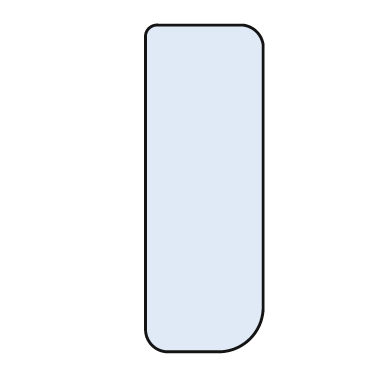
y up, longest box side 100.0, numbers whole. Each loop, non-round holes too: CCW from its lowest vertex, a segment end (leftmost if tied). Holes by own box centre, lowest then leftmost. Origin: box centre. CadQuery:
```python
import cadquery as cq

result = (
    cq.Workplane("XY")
    .moveTo(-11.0, -50.0)
    .lineTo(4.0, -50.0)
    .threePointArc((14.0, -46.0), (18.0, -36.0))
    .lineTo(18.0, 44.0)
    .threePointArc((16.0, 48.0), (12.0, 50.0))
    .lineTo(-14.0, 50.0)
    .threePointArc((-17.0, 49.0), (-18.0, 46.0))
    .lineTo(-18.0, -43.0)
    .threePointArc((-16.0, -48.0), (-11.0, -50.0))
    .close()
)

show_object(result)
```